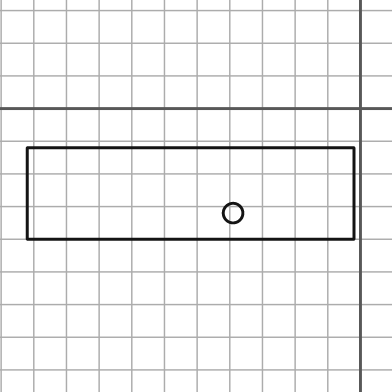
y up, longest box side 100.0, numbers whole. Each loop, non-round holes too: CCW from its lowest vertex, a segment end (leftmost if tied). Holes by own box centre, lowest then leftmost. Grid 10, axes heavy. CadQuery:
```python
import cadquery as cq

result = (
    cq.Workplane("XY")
    .moveTo(-102.0, -40.0)
    .lineTo(-2.0, -40.0)
    .lineTo(-2.0, -12.0)
    .lineTo(-102.0, -12.0)
    .close()
    .moveTo(-39.0, -32.0)
    .circle(3.0)
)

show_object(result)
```